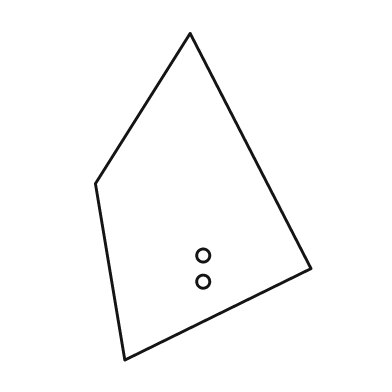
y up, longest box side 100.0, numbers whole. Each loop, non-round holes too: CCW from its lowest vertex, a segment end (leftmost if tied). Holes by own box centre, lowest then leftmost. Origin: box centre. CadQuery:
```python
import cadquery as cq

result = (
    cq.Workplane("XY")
    .moveTo(-24.0, -50.0)
    .lineTo(33.0, -22.0)
    .lineTo(-4.0, 50.0)
    .lineTo(-33.0, 4.0)
    .close()
    .moveTo(0.0, -26.0)
    .circle(2.0)
    .moveTo(0.0, -18.0)
    .circle(2.0)
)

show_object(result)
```